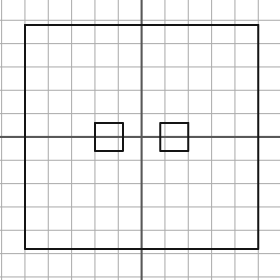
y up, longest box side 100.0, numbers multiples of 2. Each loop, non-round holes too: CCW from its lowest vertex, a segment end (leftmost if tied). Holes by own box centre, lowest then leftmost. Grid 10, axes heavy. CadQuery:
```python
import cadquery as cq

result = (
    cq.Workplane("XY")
    .moveTo(-50.0, -48.0)
    .lineTo(50.0, -48.0)
    .lineTo(50.0, 48.0)
    .lineTo(-50.0, 48.0)
    .close()
    .moveTo(-20.0, -6.0)
    .lineTo(-8.0, -6.0)
    .lineTo(-8.0, 6.0)
    .lineTo(-20.0, 6.0)
    .close()
    .moveTo(8.0, -6.0)
    .lineTo(20.0, -6.0)
    .lineTo(20.0, 6.0)
    .lineTo(8.0, 6.0)
    .close()
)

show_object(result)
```